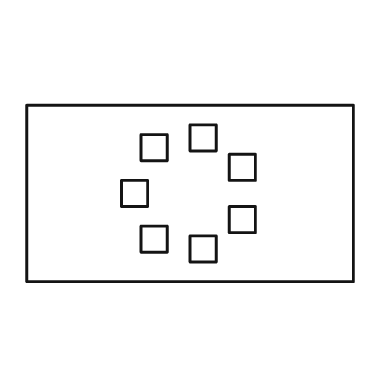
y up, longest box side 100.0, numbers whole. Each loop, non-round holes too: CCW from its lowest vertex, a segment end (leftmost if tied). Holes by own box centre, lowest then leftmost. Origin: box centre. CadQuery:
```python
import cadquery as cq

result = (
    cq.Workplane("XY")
    .moveTo(-50.0, -27.0)
    .lineTo(50.0, -27.0)
    .lineTo(50.0, 27.0)
    .lineTo(-50.0, 27.0)
    .close()
    .moveTo(0.0, -21.0)
    .lineTo(8.0, -21.0)
    .lineTo(8.0, -13.0)
    .lineTo(0.0, -13.0)
    .close()
    .moveTo(-15.0, -18.0)
    .lineTo(-7.0, -18.0)
    .lineTo(-7.0, -10.0)
    .lineTo(-15.0, -10.0)
    .close()
    .moveTo(12.0, -12.0)
    .lineTo(20.0, -12.0)
    .lineTo(20.0, -4.0)
    .lineTo(12.0, -4.0)
    .close()
    .moveTo(-21.0, -4.0)
    .lineTo(-13.0, -4.0)
    .lineTo(-13.0, 4.0)
    .lineTo(-21.0, 4.0)
    .close()
    .moveTo(12.0, 4.0)
    .lineTo(20.0, 4.0)
    .lineTo(20.0, 12.0)
    .lineTo(12.0, 12.0)
    .close()
    .moveTo(-15.0, 10.0)
    .lineTo(-7.0, 10.0)
    .lineTo(-7.0, 18.0)
    .lineTo(-15.0, 18.0)
    .close()
    .moveTo(0.0, 13.0)
    .lineTo(8.0, 13.0)
    .lineTo(8.0, 21.0)
    .lineTo(0.0, 21.0)
    .close()
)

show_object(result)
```